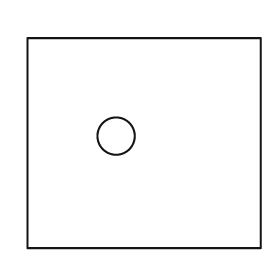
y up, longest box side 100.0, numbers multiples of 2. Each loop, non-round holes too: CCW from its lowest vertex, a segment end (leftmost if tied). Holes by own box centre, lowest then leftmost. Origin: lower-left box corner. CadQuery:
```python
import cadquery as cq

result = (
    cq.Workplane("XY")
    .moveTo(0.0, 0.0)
    .lineTo(100.0, 0.0)
    .lineTo(100.0, 90.0)
    .lineTo(0.0, 90.0)
    .close()
    .moveTo(38.0, 48.0)
    .circle(8.0)
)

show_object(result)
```